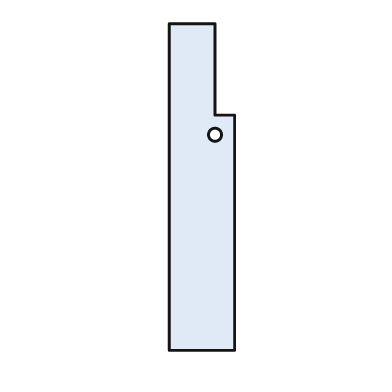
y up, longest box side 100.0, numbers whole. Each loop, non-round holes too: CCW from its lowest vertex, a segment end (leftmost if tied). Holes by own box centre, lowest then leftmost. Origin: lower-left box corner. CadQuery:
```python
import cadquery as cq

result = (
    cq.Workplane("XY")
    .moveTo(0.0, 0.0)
    .lineTo(20.0, 0.0)
    .lineTo(20.0, 72.0)
    .lineTo(14.0, 72.0)
    .lineTo(14.0, 100.0)
    .lineTo(0.0, 100.0)
    .close()
    .moveTo(14.0, 66.0)
    .circle(2.0)
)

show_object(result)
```